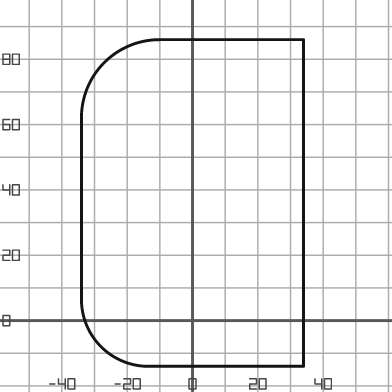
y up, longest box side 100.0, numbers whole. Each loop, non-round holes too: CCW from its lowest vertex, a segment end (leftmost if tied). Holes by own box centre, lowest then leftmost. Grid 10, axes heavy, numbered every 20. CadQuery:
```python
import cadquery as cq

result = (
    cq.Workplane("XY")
    .moveTo(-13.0, -14.0)
    .lineTo(34.0, -14.0)
    .lineTo(34.0, 86.0)
    .lineTo(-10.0, 86.0)
    .threePointArc((-27.0, 79.0), (-34.0, 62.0))
    .lineTo(-34.0, 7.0)
    .threePointArc((-28.0, -8.0), (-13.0, -14.0))
    .close()
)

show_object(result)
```